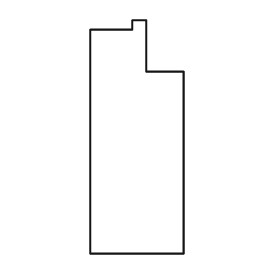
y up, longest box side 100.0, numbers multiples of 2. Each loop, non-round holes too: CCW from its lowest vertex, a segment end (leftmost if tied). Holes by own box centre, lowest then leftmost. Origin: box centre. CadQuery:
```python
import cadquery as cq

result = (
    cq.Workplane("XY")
    .moveTo(-20.0, -50.0)
    .lineTo(20.0, -50.0)
    .lineTo(20.0, 28.0)
    .lineTo(4.0, 28.0)
    .lineTo(4.0, 50.0)
    .lineTo(-2.0, 50.0)
    .lineTo(-2.0, 46.0)
    .lineTo(-20.0, 46.0)
    .close()
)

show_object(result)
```